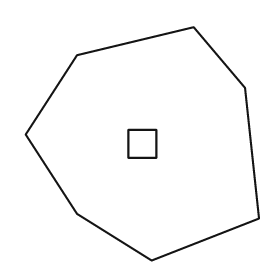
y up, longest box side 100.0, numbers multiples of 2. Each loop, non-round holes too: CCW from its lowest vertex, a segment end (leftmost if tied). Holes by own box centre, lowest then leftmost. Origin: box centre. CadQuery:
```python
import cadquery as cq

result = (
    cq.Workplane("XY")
    .moveTo(4.0, -50.0)
    .lineTo(50.0, -32.0)
    .lineTo(44.0, 24.0)
    .lineTo(22.0, 50.0)
    .lineTo(-28.0, 38.0)
    .lineTo(-50.0, 4.0)
    .lineTo(-28.0, -30.0)
    .close()
    .moveTo(-6.0, -6.0)
    .lineTo(6.0, -6.0)
    .lineTo(6.0, 6.0)
    .lineTo(-6.0, 6.0)
    .close()
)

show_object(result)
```